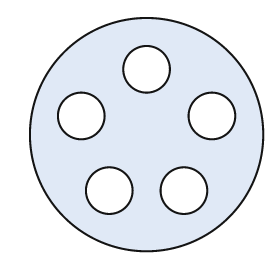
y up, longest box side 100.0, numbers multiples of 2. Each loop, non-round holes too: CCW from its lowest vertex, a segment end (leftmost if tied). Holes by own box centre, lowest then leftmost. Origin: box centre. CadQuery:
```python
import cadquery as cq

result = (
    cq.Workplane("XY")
    .moveTo(0.0, 0.0)
    .circle(50.0)
    .moveTo(-16.0, -24.0)
    .circle(10.0)
    .moveTo(16.0, -24.0)
    .circle(10.0)
    .moveTo(-28.0, 8.0)
    .circle(10.0)
    .moveTo(28.0, 8.0)
    .circle(10.0)
    .moveTo(0.0, 28.0)
    .circle(10.0)
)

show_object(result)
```